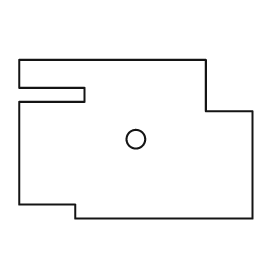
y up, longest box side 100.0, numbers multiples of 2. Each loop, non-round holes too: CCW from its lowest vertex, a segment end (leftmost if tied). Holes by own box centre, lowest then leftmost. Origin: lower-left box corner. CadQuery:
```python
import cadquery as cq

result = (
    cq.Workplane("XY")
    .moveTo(24.0, 0.0)
    .lineTo(100.0, 0.0)
    .lineTo(100.0, 46.0)
    .lineTo(80.0, 46.0)
    .lineTo(80.0, 68.0)
    .lineTo(0.0, 68.0)
    .lineTo(0.0, 56.0)
    .lineTo(28.0, 56.0)
    .lineTo(28.0, 50.0)
    .lineTo(0.0, 50.0)
    .lineTo(0.0, 6.0)
    .lineTo(24.0, 6.0)
    .close()
    .moveTo(50.0, 34.0)
    .circle(4.0)
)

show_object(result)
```